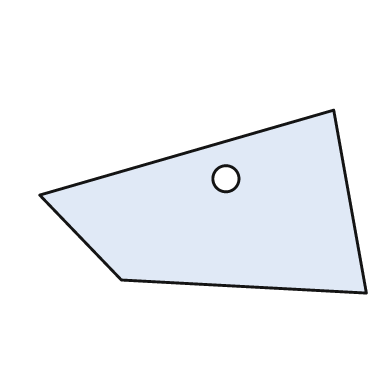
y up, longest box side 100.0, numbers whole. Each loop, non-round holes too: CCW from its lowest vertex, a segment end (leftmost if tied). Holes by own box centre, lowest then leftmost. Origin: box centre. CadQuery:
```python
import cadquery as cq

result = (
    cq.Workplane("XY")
    .moveTo(50.0, -28.0)
    .lineTo(40.0, 28.0)
    .lineTo(-50.0, 2.0)
    .lineTo(-25.0, -24.0)
    .close()
    .moveTo(7.0, 7.0)
    .circle(4.0)
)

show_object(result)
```